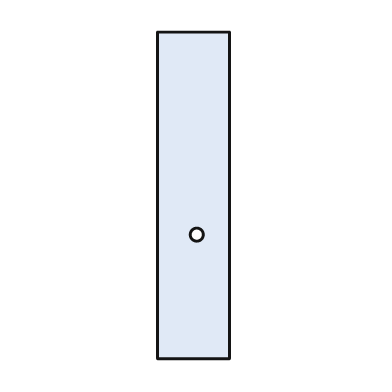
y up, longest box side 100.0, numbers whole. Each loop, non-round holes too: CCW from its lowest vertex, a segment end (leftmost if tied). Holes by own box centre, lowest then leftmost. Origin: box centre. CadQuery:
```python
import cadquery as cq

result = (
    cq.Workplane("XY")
    .moveTo(-11.0, -50.0)
    .lineTo(11.0, -50.0)
    .lineTo(11.0, 50.0)
    .lineTo(-11.0, 50.0)
    .close()
    .moveTo(1.0, -12.0)
    .circle(2.0)
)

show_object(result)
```